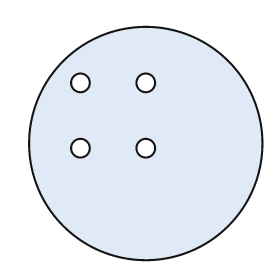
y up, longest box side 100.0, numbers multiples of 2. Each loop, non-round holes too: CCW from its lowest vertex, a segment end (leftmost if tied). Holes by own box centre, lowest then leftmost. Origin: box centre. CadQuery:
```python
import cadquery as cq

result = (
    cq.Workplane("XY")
    .moveTo(0.0, 0.0)
    .circle(50.0)
    .moveTo(-28.0, -2.0)
    .circle(4.0)
    .moveTo(0.0, -2.0)
    .circle(4.0)
    .moveTo(-28.0, 26.0)
    .circle(4.0)
    .moveTo(0.0, 26.0)
    .circle(4.0)
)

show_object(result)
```